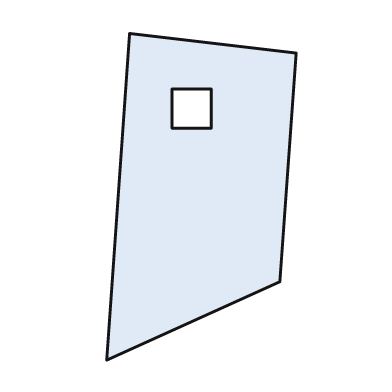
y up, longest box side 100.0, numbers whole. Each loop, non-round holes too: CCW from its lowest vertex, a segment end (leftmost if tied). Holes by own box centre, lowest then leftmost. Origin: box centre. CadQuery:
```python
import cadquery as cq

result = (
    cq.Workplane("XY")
    .moveTo(-29.0, -50.0)
    .lineTo(24.0, -26.0)
    .lineTo(29.0, 44.0)
    .lineTo(-22.0, 50.0)
    .close()
    .moveTo(-9.0, 21.0)
    .lineTo(3.0, 21.0)
    .lineTo(3.0, 33.0)
    .lineTo(-9.0, 33.0)
    .close()
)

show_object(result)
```